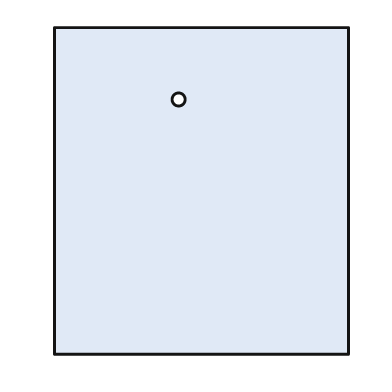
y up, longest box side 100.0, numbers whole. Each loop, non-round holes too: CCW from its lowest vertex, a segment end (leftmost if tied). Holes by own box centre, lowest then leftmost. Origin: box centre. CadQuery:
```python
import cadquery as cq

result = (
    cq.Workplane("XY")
    .moveTo(-45.0, -50.0)
    .lineTo(45.0, -50.0)
    .lineTo(45.0, 50.0)
    .lineTo(-45.0, 50.0)
    .close()
    .moveTo(-7.0, 28.0)
    .circle(2.0)
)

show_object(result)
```